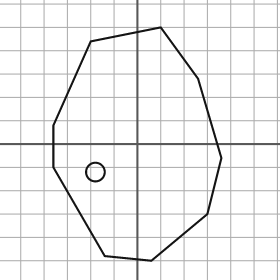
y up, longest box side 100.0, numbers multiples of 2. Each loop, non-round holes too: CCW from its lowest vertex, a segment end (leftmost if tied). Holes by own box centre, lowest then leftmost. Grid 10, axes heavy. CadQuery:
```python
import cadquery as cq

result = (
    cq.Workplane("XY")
    .moveTo(6.0, -50.0)
    .lineTo(30.0, -30.0)
    .lineTo(36.0, -6.0)
    .lineTo(26.0, 28.0)
    .lineTo(10.0, 50.0)
    .lineTo(-20.0, 44.0)
    .lineTo(-36.0, 8.0)
    .lineTo(-36.0, -10.0)
    .lineTo(-14.0, -48.0)
    .close()
    .moveTo(-18.0, -12.0)
    .circle(4.0)
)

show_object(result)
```